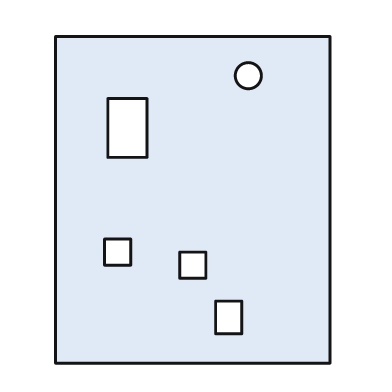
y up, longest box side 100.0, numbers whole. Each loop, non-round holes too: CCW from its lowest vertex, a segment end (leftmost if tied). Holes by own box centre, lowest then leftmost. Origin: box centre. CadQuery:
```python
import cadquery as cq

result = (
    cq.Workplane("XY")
    .moveTo(-42.0, -50.0)
    .lineTo(42.0, -50.0)
    .lineTo(42.0, 50.0)
    .lineTo(-42.0, 50.0)
    .close()
    .moveTo(7.0, -41.0)
    .lineTo(15.0, -41.0)
    .lineTo(15.0, -31.0)
    .lineTo(7.0, -31.0)
    .close()
    .moveTo(-4.0, -24.0)
    .lineTo(4.0, -24.0)
    .lineTo(4.0, -16.0)
    .lineTo(-4.0, -16.0)
    .close()
    .moveTo(-27.0, -20.0)
    .lineTo(-19.0, -20.0)
    .lineTo(-19.0, -12.0)
    .lineTo(-27.0, -12.0)
    .close()
    .moveTo(-26.0, 13.0)
    .lineTo(-14.0, 13.0)
    .lineTo(-14.0, 31.0)
    .lineTo(-26.0, 31.0)
    .close()
    .moveTo(17.0, 38.0)
    .circle(4.0)
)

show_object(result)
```